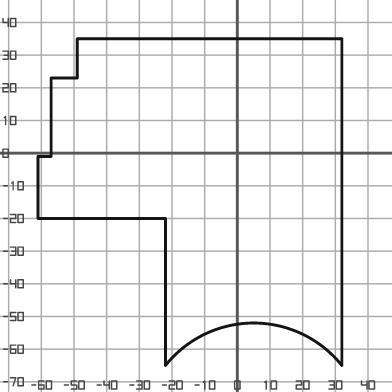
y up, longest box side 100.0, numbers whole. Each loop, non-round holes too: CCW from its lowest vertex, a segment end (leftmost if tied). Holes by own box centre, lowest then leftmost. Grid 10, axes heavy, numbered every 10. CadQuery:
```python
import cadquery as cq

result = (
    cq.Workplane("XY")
    .moveTo(-22.0, -65.0)
    .threePointArc((5.0, -52.0), (32.0, -65.0))
    .lineTo(32.0, 35.0)
    .lineTo(-49.0, 35.0)
    .lineTo(-49.0, 23.0)
    .lineTo(-57.0, 23.0)
    .lineTo(-57.0, -1.0)
    .lineTo(-61.0, -1.0)
    .lineTo(-61.0, -20.0)
    .lineTo(-22.0, -20.0)
    .close()
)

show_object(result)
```